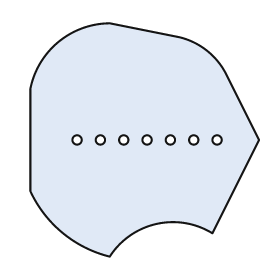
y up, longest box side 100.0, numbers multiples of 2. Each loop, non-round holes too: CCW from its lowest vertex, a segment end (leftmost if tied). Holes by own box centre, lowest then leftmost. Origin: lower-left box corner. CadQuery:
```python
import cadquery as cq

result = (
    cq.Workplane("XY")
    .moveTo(34.0, 0.0)
    .threePointArc((54.0, 14.0), (78.0, 10.0))
    .lineTo(98.0, 50.0)
    .lineTo(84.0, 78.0)
    .threePointArc((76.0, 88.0), (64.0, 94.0))
    .lineTo(34.0, 100.0)
    .threePointArc((12.0, 92.0), (0.0, 72.0))
    .lineTo(0.0, 28.0)
    .threePointArc((14.0, 10.0), (34.0, 0.0))
    .close()
    .moveTo(20.0, 50.0)
    .circle(2.0)
    .moveTo(30.0, 50.0)
    .circle(2.0)
    .moveTo(40.0, 50.0)
    .circle(2.0)
    .moveTo(50.0, 50.0)
    .circle(2.0)
    .moveTo(60.0, 50.0)
    .circle(2.0)
    .moveTo(70.0, 50.0)
    .circle(2.0)
    .moveTo(80.0, 50.0)
    .circle(2.0)
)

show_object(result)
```